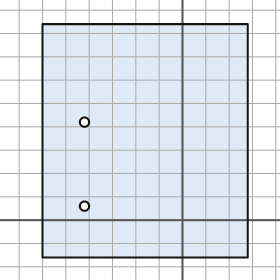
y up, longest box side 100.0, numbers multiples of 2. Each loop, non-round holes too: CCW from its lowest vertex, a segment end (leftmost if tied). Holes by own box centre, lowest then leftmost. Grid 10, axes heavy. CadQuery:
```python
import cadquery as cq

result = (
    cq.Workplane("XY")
    .moveTo(-60.0, -16.0)
    .lineTo(28.0, -16.0)
    .lineTo(28.0, 84.0)
    .lineTo(-60.0, 84.0)
    .close()
    .moveTo(-42.0, 6.0)
    .circle(2.0)
    .moveTo(-42.0, 42.0)
    .circle(2.0)
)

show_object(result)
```